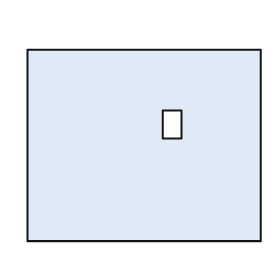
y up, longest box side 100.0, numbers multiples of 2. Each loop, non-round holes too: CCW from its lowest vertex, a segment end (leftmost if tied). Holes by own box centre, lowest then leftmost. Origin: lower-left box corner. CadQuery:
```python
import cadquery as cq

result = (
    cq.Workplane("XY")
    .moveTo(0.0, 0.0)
    .lineTo(100.0, 0.0)
    .lineTo(100.0, 82.0)
    .lineTo(0.0, 82.0)
    .close()
    .moveTo(58.0, 44.0)
    .lineTo(66.0, 44.0)
    .lineTo(66.0, 56.0)
    .lineTo(58.0, 56.0)
    .close()
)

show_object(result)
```